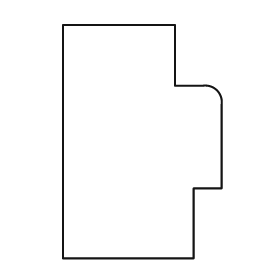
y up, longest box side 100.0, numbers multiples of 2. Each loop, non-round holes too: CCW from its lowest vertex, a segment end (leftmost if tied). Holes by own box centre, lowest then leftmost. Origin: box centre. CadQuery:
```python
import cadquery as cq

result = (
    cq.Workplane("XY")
    .moveTo(-34.0, -50.0)
    .lineTo(22.0, -50.0)
    .lineTo(22.0, -20.0)
    .lineTo(34.0, -20.0)
    .lineTo(34.0, 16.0)
    .threePointArc((32.0, 22.0), (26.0, 24.0))
    .lineTo(14.0, 24.0)
    .lineTo(14.0, 50.0)
    .lineTo(-34.0, 50.0)
    .close()
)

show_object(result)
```